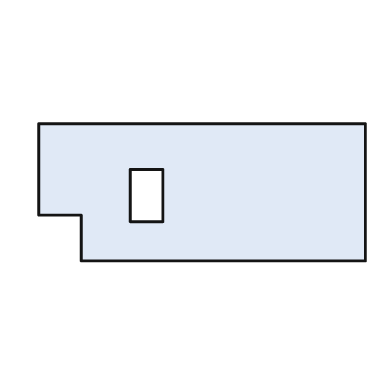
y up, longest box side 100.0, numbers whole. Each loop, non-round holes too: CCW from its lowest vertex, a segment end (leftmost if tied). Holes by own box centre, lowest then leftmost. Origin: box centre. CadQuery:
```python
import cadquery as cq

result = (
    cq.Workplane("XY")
    .moveTo(-37.0, -21.0)
    .lineTo(50.0, -21.0)
    .lineTo(50.0, 21.0)
    .lineTo(-50.0, 21.0)
    .lineTo(-50.0, -7.0)
    .lineTo(-37.0, -7.0)
    .close()
    .moveTo(-22.0, -9.0)
    .lineTo(-12.0, -9.0)
    .lineTo(-12.0, 7.0)
    .lineTo(-22.0, 7.0)
    .close()
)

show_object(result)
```